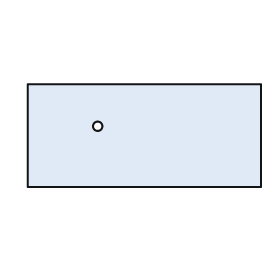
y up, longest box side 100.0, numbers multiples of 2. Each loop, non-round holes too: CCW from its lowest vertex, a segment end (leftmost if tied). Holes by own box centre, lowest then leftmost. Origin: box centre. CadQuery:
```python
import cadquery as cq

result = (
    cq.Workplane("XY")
    .moveTo(-50.0, -22.0)
    .lineTo(50.0, -22.0)
    .lineTo(50.0, 22.0)
    .lineTo(-50.0, 22.0)
    .close()
    .moveTo(-20.0, 4.0)
    .circle(2.0)
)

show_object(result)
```